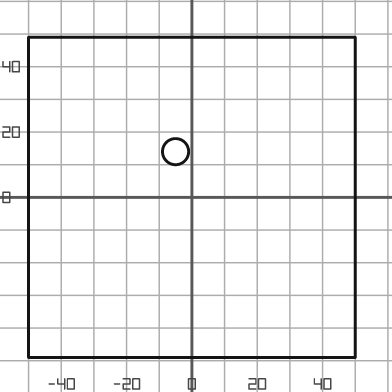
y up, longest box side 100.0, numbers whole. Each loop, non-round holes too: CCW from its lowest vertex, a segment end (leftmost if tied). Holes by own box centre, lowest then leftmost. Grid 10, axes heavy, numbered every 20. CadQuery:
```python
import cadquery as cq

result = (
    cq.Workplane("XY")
    .moveTo(-50.0, -49.0)
    .lineTo(50.0, -49.0)
    .lineTo(50.0, 49.0)
    .lineTo(-50.0, 49.0)
    .close()
    .moveTo(-5.0, 14.0)
    .circle(4.0)
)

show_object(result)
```